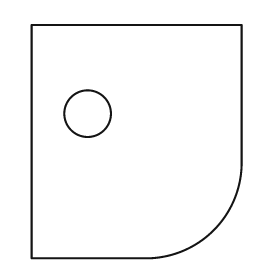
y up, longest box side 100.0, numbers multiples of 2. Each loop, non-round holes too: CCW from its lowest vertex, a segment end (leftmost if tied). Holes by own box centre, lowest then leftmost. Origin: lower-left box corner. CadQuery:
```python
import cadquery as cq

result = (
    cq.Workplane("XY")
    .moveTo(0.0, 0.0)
    .lineTo(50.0, 0.0)
    .threePointArc((78.0, 12.0), (90.0, 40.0))
    .lineTo(90.0, 100.0)
    .lineTo(0.0, 100.0)
    .close()
    .moveTo(24.0, 62.0)
    .circle(10.0)
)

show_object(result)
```